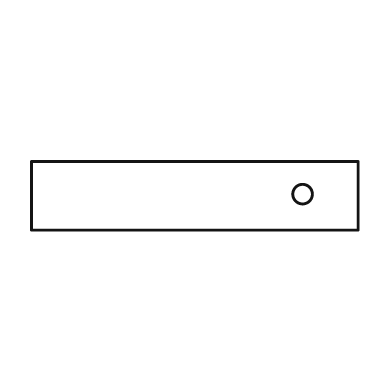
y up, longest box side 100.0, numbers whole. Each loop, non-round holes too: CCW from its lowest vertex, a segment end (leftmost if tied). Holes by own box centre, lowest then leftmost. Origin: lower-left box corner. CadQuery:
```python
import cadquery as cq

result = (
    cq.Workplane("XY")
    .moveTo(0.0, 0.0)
    .lineTo(100.0, 0.0)
    .lineTo(100.0, 21.0)
    .lineTo(0.0, 21.0)
    .close()
    .moveTo(83.0, 11.0)
    .circle(3.0)
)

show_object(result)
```